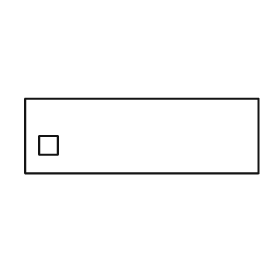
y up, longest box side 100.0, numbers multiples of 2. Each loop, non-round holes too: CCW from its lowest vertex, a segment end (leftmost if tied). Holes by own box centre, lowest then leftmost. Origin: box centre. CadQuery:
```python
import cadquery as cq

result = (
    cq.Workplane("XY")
    .moveTo(-50.0, -16.0)
    .lineTo(50.0, -16.0)
    .lineTo(50.0, 16.0)
    .lineTo(-50.0, 16.0)
    .close()
    .moveTo(-44.0, -8.0)
    .lineTo(-36.0, -8.0)
    .lineTo(-36.0, 0.0)
    .lineTo(-44.0, 0.0)
    .close()
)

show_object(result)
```